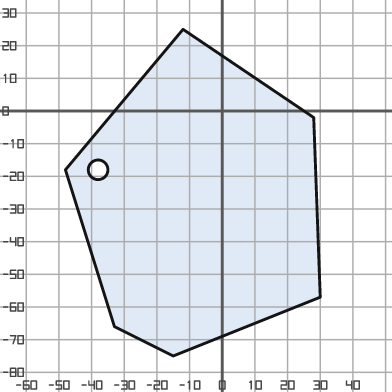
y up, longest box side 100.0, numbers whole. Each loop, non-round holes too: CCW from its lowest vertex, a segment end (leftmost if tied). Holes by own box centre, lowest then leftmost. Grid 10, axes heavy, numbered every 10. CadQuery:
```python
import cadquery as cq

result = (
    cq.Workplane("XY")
    .moveTo(-15.0, -75.0)
    .lineTo(30.0, -57.0)
    .lineTo(28.0, -2.0)
    .lineTo(-12.0, 25.0)
    .lineTo(-48.0, -18.0)
    .lineTo(-33.0, -66.0)
    .close()
    .moveTo(-38.0, -18.0)
    .circle(3.0)
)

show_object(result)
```